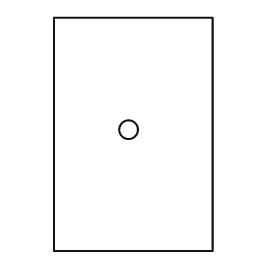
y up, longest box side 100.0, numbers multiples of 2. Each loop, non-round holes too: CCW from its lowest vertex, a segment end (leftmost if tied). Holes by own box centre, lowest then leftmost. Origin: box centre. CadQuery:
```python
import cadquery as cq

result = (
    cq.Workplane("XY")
    .moveTo(-34.0, -50.0)
    .lineTo(34.0, -50.0)
    .lineTo(34.0, 50.0)
    .lineTo(-34.0, 50.0)
    .close()
    .moveTo(-2.0, 2.0)
    .circle(4.0)
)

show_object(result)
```